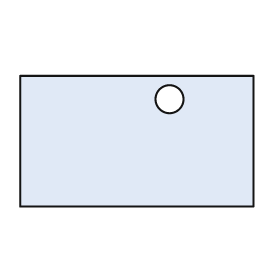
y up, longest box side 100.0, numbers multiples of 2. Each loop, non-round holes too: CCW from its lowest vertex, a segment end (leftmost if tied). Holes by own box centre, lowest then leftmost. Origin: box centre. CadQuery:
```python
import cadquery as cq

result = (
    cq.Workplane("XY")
    .moveTo(-50.0, -28.0)
    .lineTo(50.0, -28.0)
    .lineTo(50.0, 28.0)
    .lineTo(-50.0, 28.0)
    .close()
    .moveTo(14.0, 18.0)
    .circle(6.0)
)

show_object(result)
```